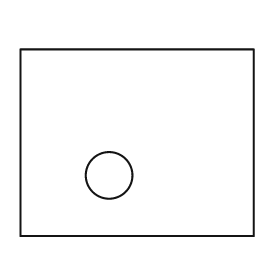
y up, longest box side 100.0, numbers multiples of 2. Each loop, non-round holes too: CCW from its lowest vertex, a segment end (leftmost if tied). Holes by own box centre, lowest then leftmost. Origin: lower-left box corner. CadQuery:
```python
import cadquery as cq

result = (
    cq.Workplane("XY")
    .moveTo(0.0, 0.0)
    .lineTo(100.0, 0.0)
    .lineTo(100.0, 80.0)
    .lineTo(0.0, 80.0)
    .close()
    .moveTo(38.0, 26.0)
    .circle(10.0)
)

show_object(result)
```